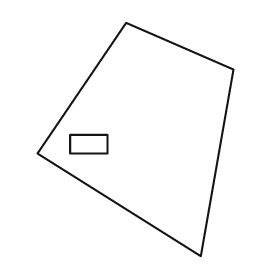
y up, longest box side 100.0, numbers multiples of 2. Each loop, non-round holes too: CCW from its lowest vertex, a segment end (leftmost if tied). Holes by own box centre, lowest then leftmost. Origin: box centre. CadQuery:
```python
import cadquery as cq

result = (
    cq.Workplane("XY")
    .moveTo(28.0, -50.0)
    .lineTo(42.0, 30.0)
    .lineTo(-4.0, 50.0)
    .lineTo(-42.0, -6.0)
    .close()
    .moveTo(-28.0, -6.0)
    .lineTo(-12.0, -6.0)
    .lineTo(-12.0, 2.0)
    .lineTo(-28.0, 2.0)
    .close()
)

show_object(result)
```